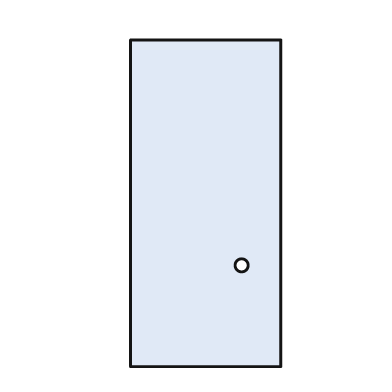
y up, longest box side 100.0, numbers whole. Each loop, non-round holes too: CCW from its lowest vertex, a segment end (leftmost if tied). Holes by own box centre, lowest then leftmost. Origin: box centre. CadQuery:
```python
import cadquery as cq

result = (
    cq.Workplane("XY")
    .moveTo(-23.0, -50.0)
    .lineTo(23.0, -50.0)
    .lineTo(23.0, 50.0)
    .lineTo(-23.0, 50.0)
    .close()
    .moveTo(11.0, -19.0)
    .circle(2.0)
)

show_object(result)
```